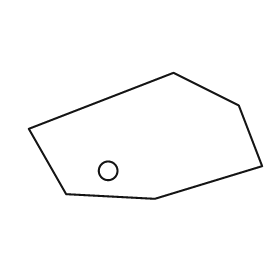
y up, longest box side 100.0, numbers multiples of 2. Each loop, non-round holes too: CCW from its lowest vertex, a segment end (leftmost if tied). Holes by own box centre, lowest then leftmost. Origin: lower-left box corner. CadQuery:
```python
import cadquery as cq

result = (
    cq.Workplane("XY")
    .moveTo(54.0, 0.0)
    .lineTo(100.0, 14.0)
    .lineTo(90.0, 40.0)
    .lineTo(62.0, 54.0)
    .lineTo(0.0, 30.0)
    .lineTo(16.0, 2.0)
    .close()
    .moveTo(34.0, 12.0)
    .circle(4.0)
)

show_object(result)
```